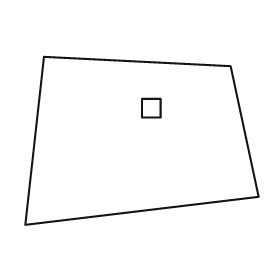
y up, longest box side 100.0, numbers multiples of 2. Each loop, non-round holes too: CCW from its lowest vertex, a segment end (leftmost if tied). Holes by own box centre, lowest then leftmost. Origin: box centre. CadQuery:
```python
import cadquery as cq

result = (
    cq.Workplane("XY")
    .moveTo(-50.0, -36.0)
    .lineTo(50.0, -24.0)
    .lineTo(38.0, 32.0)
    .lineTo(-42.0, 36.0)
    .close()
    .moveTo(0.0, 10.0)
    .lineTo(8.0, 10.0)
    .lineTo(8.0, 18.0)
    .lineTo(0.0, 18.0)
    .close()
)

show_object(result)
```